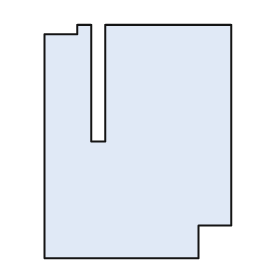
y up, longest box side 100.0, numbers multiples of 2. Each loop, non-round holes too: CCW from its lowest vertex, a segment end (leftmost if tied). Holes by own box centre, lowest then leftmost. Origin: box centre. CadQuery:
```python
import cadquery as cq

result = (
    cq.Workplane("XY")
    .moveTo(-40.0, -50.0)
    .lineTo(26.0, -50.0)
    .lineTo(26.0, -36.0)
    .lineTo(40.0, -36.0)
    .lineTo(40.0, 50.0)
    .lineTo(-14.0, 50.0)
    .lineTo(-14.0, 0.0)
    .lineTo(-20.0, 0.0)
    .lineTo(-20.0, 50.0)
    .lineTo(-26.0, 50.0)
    .lineTo(-26.0, 46.0)
    .lineTo(-40.0, 46.0)
    .close()
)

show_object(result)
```